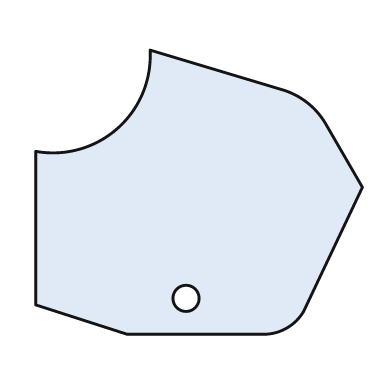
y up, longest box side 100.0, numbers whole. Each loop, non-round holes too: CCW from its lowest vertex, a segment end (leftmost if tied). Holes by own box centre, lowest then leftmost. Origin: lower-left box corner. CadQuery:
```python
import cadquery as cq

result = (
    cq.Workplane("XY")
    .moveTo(28.0, 0.0)
    .lineTo(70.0, 0.0)
    .threePointArc((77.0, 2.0), (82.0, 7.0))
    .lineTo(100.0, 45.0)
    .lineTo(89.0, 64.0)
    .threePointArc((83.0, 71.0), (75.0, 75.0))
    .lineTo(35.0, 87.0)
    .threePointArc((25.0, 63.0), (0.0, 56.0))
    .lineTo(0.0, 9.0)
    .close()
    .moveTo(46.0, 11.0)
    .circle(4.0)
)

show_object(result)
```